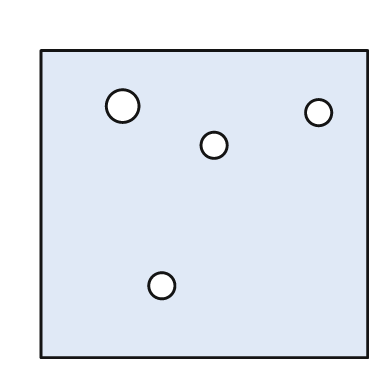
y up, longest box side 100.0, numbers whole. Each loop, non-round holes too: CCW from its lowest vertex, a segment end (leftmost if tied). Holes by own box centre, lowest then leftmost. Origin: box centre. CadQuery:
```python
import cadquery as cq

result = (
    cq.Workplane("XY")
    .moveTo(-50.0, -47.0)
    .lineTo(50.0, -47.0)
    .lineTo(50.0, 47.0)
    .lineTo(-50.0, 47.0)
    .close()
    .moveTo(-13.0, -25.0)
    .circle(4.0)
    .moveTo(3.0, 18.0)
    .circle(4.0)
    .moveTo(35.0, 28.0)
    .circle(4.0)
    .moveTo(-25.0, 30.0)
    .circle(5.0)
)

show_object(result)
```